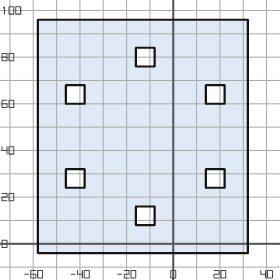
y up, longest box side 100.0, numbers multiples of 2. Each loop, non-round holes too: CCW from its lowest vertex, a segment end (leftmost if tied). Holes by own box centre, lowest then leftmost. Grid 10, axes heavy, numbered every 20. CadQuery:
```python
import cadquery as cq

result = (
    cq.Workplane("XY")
    .moveTo(-58.0, -4.0)
    .lineTo(32.0, -4.0)
    .lineTo(32.0, 96.0)
    .lineTo(-58.0, 96.0)
    .close()
    .moveTo(-16.0, 8.0)
    .lineTo(-8.0, 8.0)
    .lineTo(-8.0, 16.0)
    .lineTo(-16.0, 16.0)
    .close()
    .moveTo(-46.0, 24.0)
    .lineTo(-38.0, 24.0)
    .lineTo(-38.0, 32.0)
    .lineTo(-46.0, 32.0)
    .close()
    .moveTo(14.0, 24.0)
    .lineTo(22.0, 24.0)
    .lineTo(22.0, 32.0)
    .lineTo(14.0, 32.0)
    .close()
    .moveTo(-46.0, 60.0)
    .lineTo(-38.0, 60.0)
    .lineTo(-38.0, 68.0)
    .lineTo(-46.0, 68.0)
    .close()
    .moveTo(14.0, 60.0)
    .lineTo(22.0, 60.0)
    .lineTo(22.0, 68.0)
    .lineTo(14.0, 68.0)
    .close()
    .moveTo(-16.0, 76.0)
    .lineTo(-8.0, 76.0)
    .lineTo(-8.0, 84.0)
    .lineTo(-16.0, 84.0)
    .close()
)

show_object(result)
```